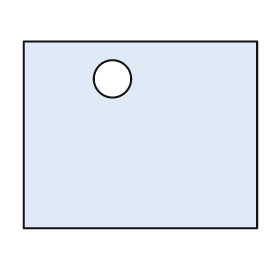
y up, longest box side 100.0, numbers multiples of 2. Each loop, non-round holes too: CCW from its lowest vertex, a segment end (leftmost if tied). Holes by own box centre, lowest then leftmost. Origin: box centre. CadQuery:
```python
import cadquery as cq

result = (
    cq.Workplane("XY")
    .moveTo(-50.0, -40.0)
    .lineTo(50.0, -40.0)
    .lineTo(50.0, 40.0)
    .lineTo(-50.0, 40.0)
    .close()
    .moveTo(-12.0, 24.0)
    .circle(8.0)
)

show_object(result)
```